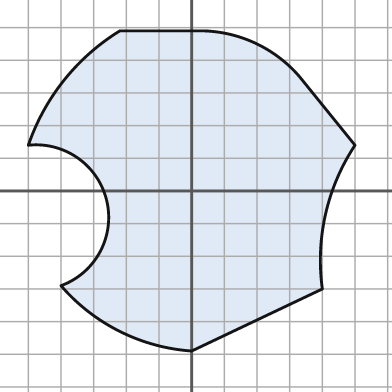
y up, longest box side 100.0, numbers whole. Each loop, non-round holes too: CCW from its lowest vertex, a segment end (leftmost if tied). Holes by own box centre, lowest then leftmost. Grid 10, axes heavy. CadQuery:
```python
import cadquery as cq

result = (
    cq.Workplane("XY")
    .moveTo(0.0, -49.0)
    .lineTo(40.0, -30.0)
    .threePointArc((41.0, -7.0), (50.0, 14.0))
    .lineTo(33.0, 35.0)
    .threePointArc((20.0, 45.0), (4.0, 49.0))
    .lineTo(-22.0, 49.0)
    .threePointArc((-39.0, 34.0), (-50.0, 14.0))
    .threePointArc((-26.0, -3.0), (-40.0, -29.0))
    .threePointArc((-22.0, -43.0), (0.0, -49.0))
    .close()
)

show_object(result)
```